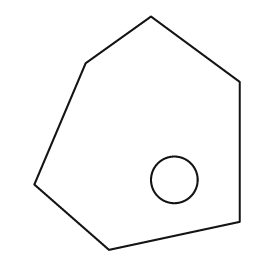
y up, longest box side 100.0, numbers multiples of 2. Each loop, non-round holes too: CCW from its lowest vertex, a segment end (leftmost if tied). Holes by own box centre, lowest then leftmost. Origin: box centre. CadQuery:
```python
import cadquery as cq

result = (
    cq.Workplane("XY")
    .moveTo(-12.0, -50.0)
    .lineTo(44.0, -38.0)
    .lineTo(44.0, 22.0)
    .lineTo(6.0, 50.0)
    .lineTo(-22.0, 30.0)
    .lineTo(-44.0, -22.0)
    .close()
    .moveTo(16.0, -20.0)
    .circle(10.0)
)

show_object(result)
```